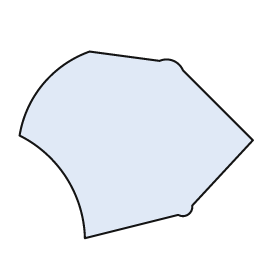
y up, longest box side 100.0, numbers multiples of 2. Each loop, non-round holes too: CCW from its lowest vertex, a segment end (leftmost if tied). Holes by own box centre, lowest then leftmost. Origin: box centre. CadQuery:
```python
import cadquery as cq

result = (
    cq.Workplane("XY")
    .moveTo(-22.0, -40.0)
    .lineTo(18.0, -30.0)
    .threePointArc((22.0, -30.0), (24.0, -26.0))
    .lineTo(50.0, 2.0)
    .lineTo(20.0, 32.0)
    .threePointArc((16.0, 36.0), (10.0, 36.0))
    .lineTo(-20.0, 40.0)
    .threePointArc((-40.0, 26.0), (-50.0, 4.0))
    .threePointArc((-30.0, -14.0), (-22.0, -40.0))
    .close()
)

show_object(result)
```